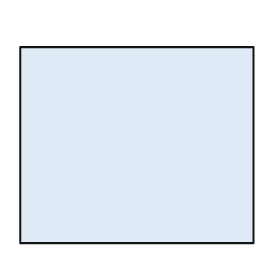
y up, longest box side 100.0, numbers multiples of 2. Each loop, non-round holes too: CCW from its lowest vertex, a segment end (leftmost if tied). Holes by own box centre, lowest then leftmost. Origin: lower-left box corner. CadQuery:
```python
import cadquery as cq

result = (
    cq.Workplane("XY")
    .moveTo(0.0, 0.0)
    .lineTo(100.0, 0.0)
    .lineTo(100.0, 84.0)
    .lineTo(0.0, 84.0)
    .close()
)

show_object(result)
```